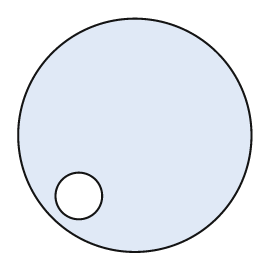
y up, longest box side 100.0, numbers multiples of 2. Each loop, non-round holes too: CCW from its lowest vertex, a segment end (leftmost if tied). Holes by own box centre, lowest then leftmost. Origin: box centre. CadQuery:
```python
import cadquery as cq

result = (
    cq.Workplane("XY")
    .moveTo(0.0, 0.0)
    .circle(50.0)
    .moveTo(-24.0, -26.0)
    .circle(10.0)
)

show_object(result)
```